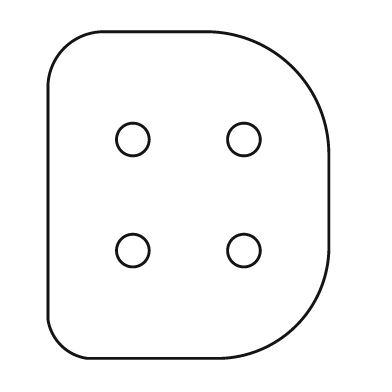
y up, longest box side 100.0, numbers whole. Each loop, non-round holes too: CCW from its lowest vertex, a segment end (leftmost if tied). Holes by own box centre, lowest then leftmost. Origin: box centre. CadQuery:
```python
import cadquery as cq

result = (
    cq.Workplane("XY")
    .moveTo(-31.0, -50.0)
    .lineTo(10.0, -50.0)
    .threePointArc((33.0, -40.0), (43.0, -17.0))
    .lineTo(43.0, 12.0)
    .threePointArc((32.0, 39.0), (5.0, 50.0))
    .lineTo(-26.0, 50.0)
    .threePointArc((-38.0, 45.0), (-43.0, 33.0))
    .lineTo(-43.0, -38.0)
    .threePointArc((-39.0, -46.0), (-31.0, -50.0))
    .close()
    .moveTo(-17.0, -17.0)
    .circle(5.0)
    .moveTo(17.0, -17.0)
    .circle(5.0)
    .moveTo(-17.0, 17.0)
    .circle(5.0)
    .moveTo(17.0, 17.0)
    .circle(5.0)
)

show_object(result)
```